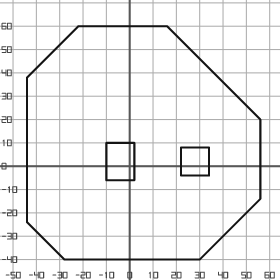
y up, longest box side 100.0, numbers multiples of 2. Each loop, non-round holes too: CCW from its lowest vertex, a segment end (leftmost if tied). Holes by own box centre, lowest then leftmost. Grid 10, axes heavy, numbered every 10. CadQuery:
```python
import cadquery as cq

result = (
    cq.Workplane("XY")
    .moveTo(-28.0, -40.0)
    .lineTo(30.0, -40.0)
    .lineTo(56.0, -14.0)
    .lineTo(56.0, 20.0)
    .lineTo(16.0, 60.0)
    .lineTo(-22.0, 60.0)
    .lineTo(-44.0, 38.0)
    .lineTo(-44.0, -24.0)
    .close()
    .moveTo(-10.0, -6.0)
    .lineTo(2.0, -6.0)
    .lineTo(2.0, 10.0)
    .lineTo(-10.0, 10.0)
    .close()
    .moveTo(22.0, -4.0)
    .lineTo(34.0, -4.0)
    .lineTo(34.0, 8.0)
    .lineTo(22.0, 8.0)
    .close()
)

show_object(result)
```